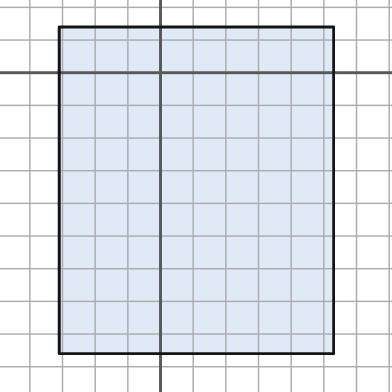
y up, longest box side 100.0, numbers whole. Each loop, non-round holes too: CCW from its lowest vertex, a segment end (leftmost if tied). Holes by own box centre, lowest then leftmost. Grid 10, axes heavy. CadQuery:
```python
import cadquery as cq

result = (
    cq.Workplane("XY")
    .moveTo(-31.0, -86.0)
    .lineTo(53.0, -86.0)
    .lineTo(53.0, 14.0)
    .lineTo(-31.0, 14.0)
    .close()
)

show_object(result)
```